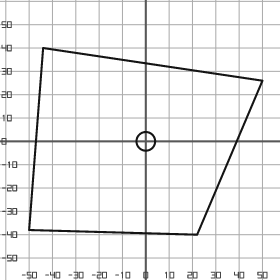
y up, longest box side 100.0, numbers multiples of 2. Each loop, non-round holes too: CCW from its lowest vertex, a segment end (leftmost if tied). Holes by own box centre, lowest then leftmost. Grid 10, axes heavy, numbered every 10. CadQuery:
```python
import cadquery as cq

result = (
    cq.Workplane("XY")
    .moveTo(22.0, -40.0)
    .lineTo(50.0, 26.0)
    .lineTo(-44.0, 40.0)
    .lineTo(-50.0, -38.0)
    .close()
    .moveTo(0.0, 0.0)
    .circle(4.0)
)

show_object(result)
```